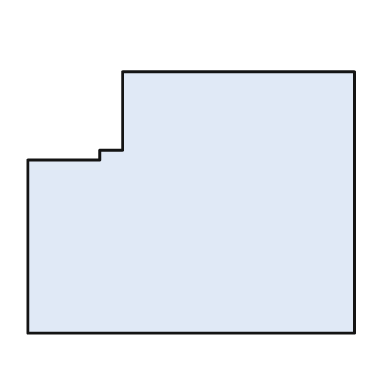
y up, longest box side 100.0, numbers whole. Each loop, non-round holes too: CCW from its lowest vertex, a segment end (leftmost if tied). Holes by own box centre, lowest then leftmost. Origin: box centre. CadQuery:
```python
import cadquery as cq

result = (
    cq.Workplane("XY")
    .moveTo(-50.0, -40.0)
    .lineTo(50.0, -40.0)
    .lineTo(50.0, 40.0)
    .lineTo(-21.0, 40.0)
    .lineTo(-21.0, 16.0)
    .lineTo(-28.0, 16.0)
    .lineTo(-28.0, 13.0)
    .lineTo(-50.0, 13.0)
    .close()
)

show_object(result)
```